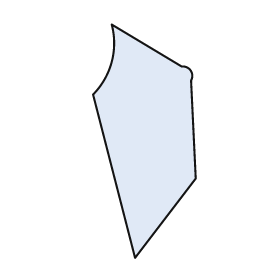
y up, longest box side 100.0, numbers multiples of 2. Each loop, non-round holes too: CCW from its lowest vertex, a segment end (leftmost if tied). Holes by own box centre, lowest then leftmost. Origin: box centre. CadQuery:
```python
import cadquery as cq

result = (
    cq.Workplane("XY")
    .moveTo(-4.0, -50.0)
    .lineTo(22.0, -16.0)
    .lineTo(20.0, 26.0)
    .threePointArc((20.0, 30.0), (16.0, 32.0))
    .lineTo(-14.0, 50.0)
    .threePointArc((-14.0, 34.0), (-22.0, 20.0))
    .close()
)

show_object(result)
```